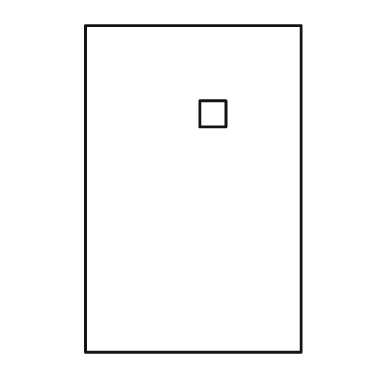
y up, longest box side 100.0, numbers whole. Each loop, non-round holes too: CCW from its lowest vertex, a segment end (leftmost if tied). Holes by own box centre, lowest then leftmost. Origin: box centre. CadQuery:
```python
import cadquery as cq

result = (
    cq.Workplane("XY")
    .moveTo(-33.0, -50.0)
    .lineTo(33.0, -50.0)
    .lineTo(33.0, 50.0)
    .lineTo(-33.0, 50.0)
    .close()
    .moveTo(2.0, 19.0)
    .lineTo(10.0, 19.0)
    .lineTo(10.0, 27.0)
    .lineTo(2.0, 27.0)
    .close()
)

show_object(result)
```